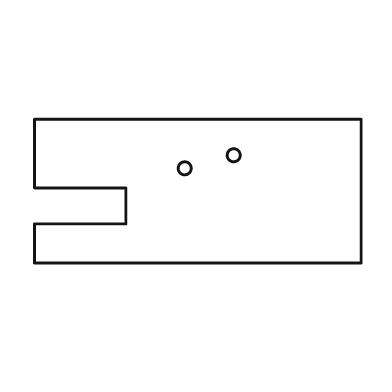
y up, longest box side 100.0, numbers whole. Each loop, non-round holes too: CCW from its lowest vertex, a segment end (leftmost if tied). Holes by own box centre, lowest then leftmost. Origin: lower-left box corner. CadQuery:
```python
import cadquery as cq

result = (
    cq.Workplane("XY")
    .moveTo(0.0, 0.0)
    .lineTo(100.0, 0.0)
    .lineTo(100.0, 44.0)
    .lineTo(0.0, 44.0)
    .lineTo(0.0, 23.0)
    .lineTo(28.0, 23.0)
    .lineTo(28.0, 12.0)
    .lineTo(0.0, 12.0)
    .close()
    .moveTo(46.0, 29.0)
    .circle(2.0)
    .moveTo(61.0, 33.0)
    .circle(2.0)
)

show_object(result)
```